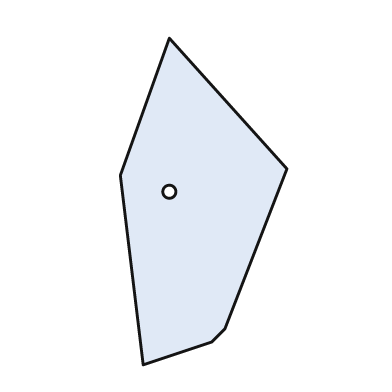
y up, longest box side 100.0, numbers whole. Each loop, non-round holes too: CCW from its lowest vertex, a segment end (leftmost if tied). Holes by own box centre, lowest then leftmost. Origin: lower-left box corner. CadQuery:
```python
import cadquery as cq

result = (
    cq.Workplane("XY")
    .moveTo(7.0, 0.0)
    .lineTo(28.0, 7.0)
    .lineTo(32.0, 11.0)
    .lineTo(51.0, 60.0)
    .lineTo(15.0, 100.0)
    .lineTo(0.0, 58.0)
    .close()
    .moveTo(15.0, 53.0)
    .circle(2.0)
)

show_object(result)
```